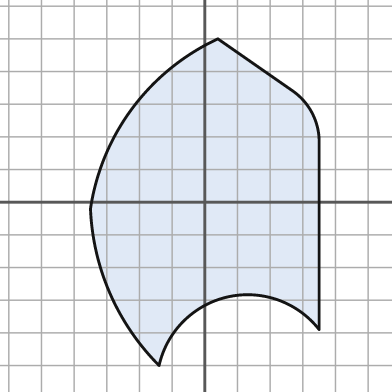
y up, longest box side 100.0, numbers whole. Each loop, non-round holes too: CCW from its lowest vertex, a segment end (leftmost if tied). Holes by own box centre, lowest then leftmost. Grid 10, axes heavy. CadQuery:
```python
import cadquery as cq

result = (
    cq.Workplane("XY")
    .moveTo(-14.0, -50.0)
    .threePointArc((7.0, -29.0), (35.0, -39.0))
    .lineTo(35.0, 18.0)
    .threePointArc((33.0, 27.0), (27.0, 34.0))
    .lineTo(4.0, 50.0)
    .threePointArc((-22.0, 29.0), (-35.0, -2.0))
    .threePointArc((-29.0, -28.0), (-14.0, -50.0))
    .close()
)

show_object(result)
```